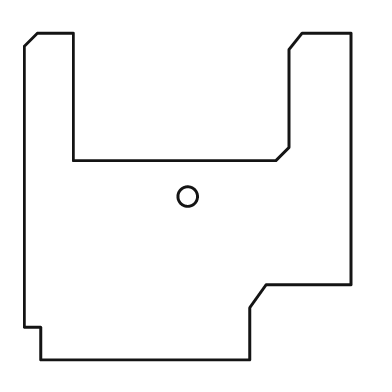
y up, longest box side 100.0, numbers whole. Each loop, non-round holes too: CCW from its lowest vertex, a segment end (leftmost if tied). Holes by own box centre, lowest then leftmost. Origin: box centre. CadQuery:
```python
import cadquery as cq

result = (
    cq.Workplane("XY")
    .moveTo(-45.0, -50.0)
    .lineTo(19.0, -50.0)
    .lineTo(19.0, -34.0)
    .lineTo(24.0, -27.0)
    .lineTo(50.0, -27.0)
    .lineTo(50.0, 50.0)
    .lineTo(35.0, 50.0)
    .lineTo(31.0, 45.0)
    .lineTo(31.0, 15.0)
    .lineTo(27.0, 11.0)
    .lineTo(-35.0, 11.0)
    .lineTo(-35.0, 50.0)
    .lineTo(-46.0, 50.0)
    .lineTo(-50.0, 46.0)
    .lineTo(-50.0, -40.0)
    .lineTo(-45.0, -40.0)
    .close()
    .moveTo(0.0, 0.0)
    .circle(3.0)
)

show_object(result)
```